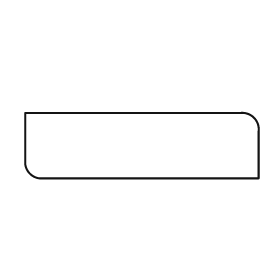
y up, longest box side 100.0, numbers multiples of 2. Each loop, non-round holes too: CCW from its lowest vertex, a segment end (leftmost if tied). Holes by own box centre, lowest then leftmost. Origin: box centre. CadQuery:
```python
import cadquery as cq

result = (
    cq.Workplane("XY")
    .moveTo(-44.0, -14.0)
    .lineTo(50.0, -14.0)
    .lineTo(50.0, 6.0)
    .threePointArc((48.0, 12.0), (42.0, 14.0))
    .lineTo(-50.0, 14.0)
    .lineTo(-50.0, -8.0)
    .threePointArc((-48.0, -12.0), (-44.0, -14.0))
    .close()
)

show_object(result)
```